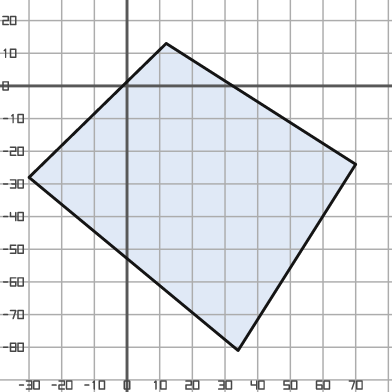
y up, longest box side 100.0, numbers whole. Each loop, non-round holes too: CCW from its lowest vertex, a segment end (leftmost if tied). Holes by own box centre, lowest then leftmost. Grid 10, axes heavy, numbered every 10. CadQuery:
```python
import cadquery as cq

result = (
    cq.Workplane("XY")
    .moveTo(34.0, -81.0)
    .lineTo(70.0, -24.0)
    .lineTo(12.0, 13.0)
    .lineTo(-30.0, -28.0)
    .close()
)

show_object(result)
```